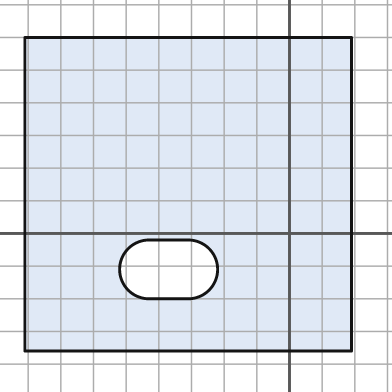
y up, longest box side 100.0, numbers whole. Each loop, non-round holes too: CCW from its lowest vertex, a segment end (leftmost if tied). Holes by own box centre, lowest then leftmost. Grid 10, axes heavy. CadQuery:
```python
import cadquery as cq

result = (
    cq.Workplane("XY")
    .moveTo(-81.0, -36.0)
    .lineTo(19.0, -36.0)
    .lineTo(19.0, 60.0)
    .lineTo(-81.0, 60.0)
    .close()
    .moveTo(-43.0, -20.0)
    .lineTo(-31.0, -20.0)
    .threePointArc((-22.0, -11.0), (-31.0, -2.0))
    .lineTo(-43.0, -2.0)
    .threePointArc((-52.0, -11.0), (-43.0, -20.0))
    .close()
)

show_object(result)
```